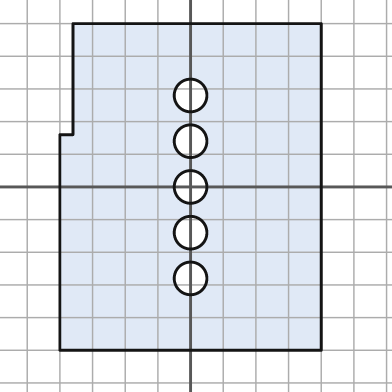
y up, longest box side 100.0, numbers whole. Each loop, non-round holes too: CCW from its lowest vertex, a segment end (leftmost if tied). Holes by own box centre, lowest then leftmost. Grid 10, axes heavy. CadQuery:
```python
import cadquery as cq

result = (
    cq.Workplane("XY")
    .moveTo(-40.0, -50.0)
    .lineTo(40.0, -50.0)
    .lineTo(40.0, 50.0)
    .lineTo(-36.0, 50.0)
    .lineTo(-36.0, 16.0)
    .lineTo(-40.0, 16.0)
    .close()
    .moveTo(0.0, -28.0)
    .circle(5.0)
    .moveTo(0.0, -14.0)
    .circle(5.0)
    .moveTo(0.0, 0.0)
    .circle(5.0)
    .moveTo(0.0, 14.0)
    .circle(5.0)
    .moveTo(0.0, 28.0)
    .circle(5.0)
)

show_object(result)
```